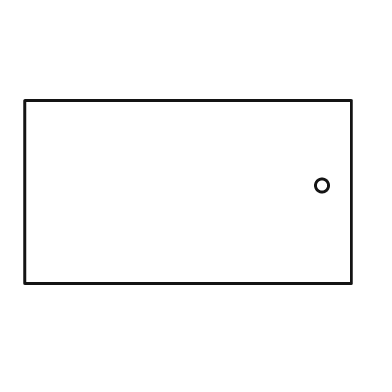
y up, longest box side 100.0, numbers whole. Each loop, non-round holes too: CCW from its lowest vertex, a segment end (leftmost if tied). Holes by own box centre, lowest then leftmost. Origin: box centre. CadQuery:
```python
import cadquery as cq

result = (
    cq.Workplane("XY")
    .moveTo(-50.0, -28.0)
    .lineTo(50.0, -28.0)
    .lineTo(50.0, 28.0)
    .lineTo(-50.0, 28.0)
    .close()
    .moveTo(41.0, 2.0)
    .circle(2.0)
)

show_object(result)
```